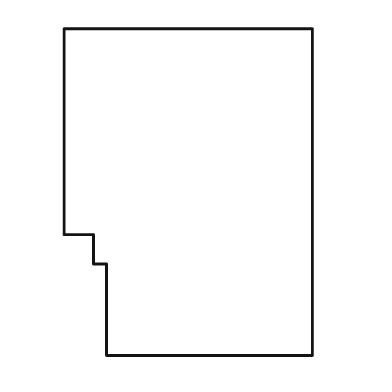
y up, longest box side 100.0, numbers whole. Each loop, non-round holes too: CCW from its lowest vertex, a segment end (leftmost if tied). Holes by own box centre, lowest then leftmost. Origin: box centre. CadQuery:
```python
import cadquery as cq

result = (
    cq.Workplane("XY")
    .moveTo(-25.0, -50.0)
    .lineTo(38.0, -50.0)
    .lineTo(38.0, 50.0)
    .lineTo(-38.0, 50.0)
    .lineTo(-38.0, -13.0)
    .lineTo(-29.0, -13.0)
    .lineTo(-29.0, -22.0)
    .lineTo(-25.0, -22.0)
    .close()
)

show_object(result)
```